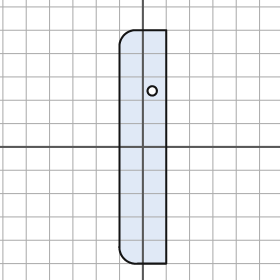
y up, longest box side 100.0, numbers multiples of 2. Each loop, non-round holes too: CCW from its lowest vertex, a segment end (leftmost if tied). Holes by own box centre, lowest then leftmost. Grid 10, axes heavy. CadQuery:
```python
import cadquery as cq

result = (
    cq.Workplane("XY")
    .moveTo(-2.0, -50.0)
    .lineTo(10.0, -50.0)
    .lineTo(10.0, 50.0)
    .lineTo(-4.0, 50.0)
    .threePointArc((-8.0, 48.0), (-10.0, 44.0))
    .lineTo(-10.0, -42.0)
    .threePointArc((-8.0, -48.0), (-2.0, -50.0))
    .close()
    .moveTo(4.0, 24.0)
    .circle(2.0)
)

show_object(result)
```